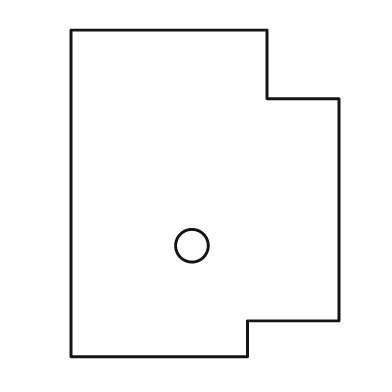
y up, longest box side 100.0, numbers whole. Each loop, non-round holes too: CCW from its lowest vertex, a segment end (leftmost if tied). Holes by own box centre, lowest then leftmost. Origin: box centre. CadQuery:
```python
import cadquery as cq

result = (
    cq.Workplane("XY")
    .moveTo(-41.0, -50.0)
    .lineTo(13.0, -50.0)
    .lineTo(13.0, -39.0)
    .lineTo(41.0, -39.0)
    .lineTo(41.0, 29.0)
    .lineTo(19.0, 29.0)
    .lineTo(19.0, 50.0)
    .lineTo(-41.0, 50.0)
    .close()
    .moveTo(-4.0, -16.0)
    .circle(5.0)
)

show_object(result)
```